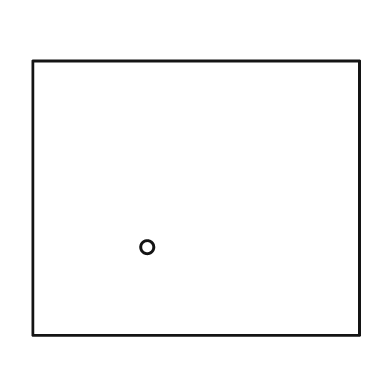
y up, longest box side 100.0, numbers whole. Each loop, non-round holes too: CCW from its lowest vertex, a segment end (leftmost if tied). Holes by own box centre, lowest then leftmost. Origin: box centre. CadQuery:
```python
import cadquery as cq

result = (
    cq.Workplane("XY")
    .moveTo(-50.0, -42.0)
    .lineTo(50.0, -42.0)
    .lineTo(50.0, 42.0)
    .lineTo(-50.0, 42.0)
    .close()
    .moveTo(-15.0, -15.0)
    .circle(2.0)
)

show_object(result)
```